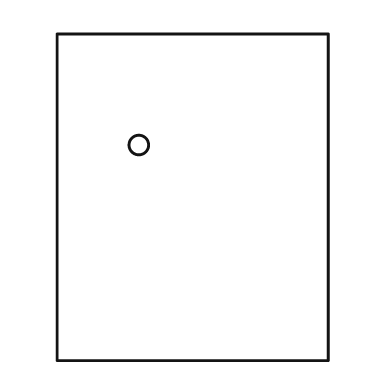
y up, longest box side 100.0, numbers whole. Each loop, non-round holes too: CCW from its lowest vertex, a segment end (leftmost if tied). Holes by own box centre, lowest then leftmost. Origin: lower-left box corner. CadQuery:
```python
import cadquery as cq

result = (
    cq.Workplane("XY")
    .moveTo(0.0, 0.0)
    .lineTo(83.0, 0.0)
    .lineTo(83.0, 100.0)
    .lineTo(0.0, 100.0)
    .close()
    .moveTo(25.0, 66.0)
    .circle(3.0)
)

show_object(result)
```